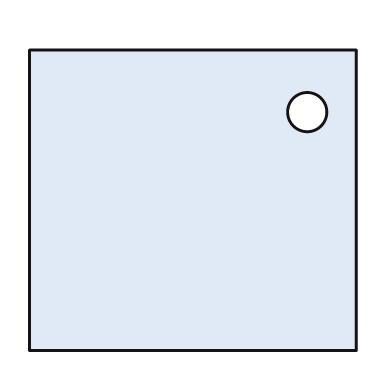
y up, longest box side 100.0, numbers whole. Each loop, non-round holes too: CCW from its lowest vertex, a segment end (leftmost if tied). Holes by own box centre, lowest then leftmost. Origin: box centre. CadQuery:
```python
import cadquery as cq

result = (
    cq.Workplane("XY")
    .moveTo(-50.0, -46.0)
    .lineTo(50.0, -46.0)
    .lineTo(50.0, 46.0)
    .lineTo(-50.0, 46.0)
    .close()
    .moveTo(35.0, 27.0)
    .circle(6.0)
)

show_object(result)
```